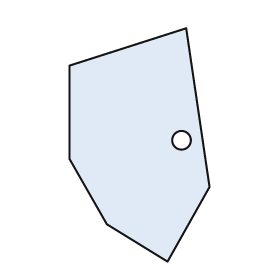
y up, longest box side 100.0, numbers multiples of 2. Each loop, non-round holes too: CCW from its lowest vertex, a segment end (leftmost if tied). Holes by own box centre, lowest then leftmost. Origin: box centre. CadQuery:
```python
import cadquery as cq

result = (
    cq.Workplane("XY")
    .moveTo(12.0, -50.0)
    .lineTo(30.0, -18.0)
    .lineTo(20.0, 50.0)
    .lineTo(-30.0, 34.0)
    .lineTo(-30.0, -6.0)
    .lineTo(-14.0, -34.0)
    .close()
    .moveTo(18.0, 2.0)
    .circle(4.0)
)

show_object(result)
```